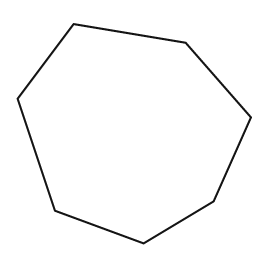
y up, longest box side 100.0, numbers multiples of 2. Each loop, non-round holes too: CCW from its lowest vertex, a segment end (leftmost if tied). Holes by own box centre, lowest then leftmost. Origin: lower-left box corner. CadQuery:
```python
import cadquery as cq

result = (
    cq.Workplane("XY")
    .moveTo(54.0, 0.0)
    .lineTo(84.0, 18.0)
    .lineTo(100.0, 54.0)
    .lineTo(72.0, 86.0)
    .lineTo(24.0, 94.0)
    .lineTo(0.0, 62.0)
    .lineTo(16.0, 14.0)
    .close()
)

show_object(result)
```